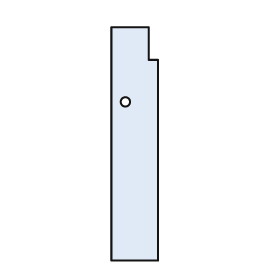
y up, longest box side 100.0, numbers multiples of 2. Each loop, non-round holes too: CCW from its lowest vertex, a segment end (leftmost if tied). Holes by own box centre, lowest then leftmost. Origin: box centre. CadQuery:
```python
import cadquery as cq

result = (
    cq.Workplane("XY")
    .moveTo(-10.0, -50.0)
    .lineTo(10.0, -50.0)
    .lineTo(10.0, 36.0)
    .lineTo(6.0, 36.0)
    .lineTo(6.0, 50.0)
    .lineTo(-10.0, 50.0)
    .close()
    .moveTo(-4.0, 18.0)
    .circle(2.0)
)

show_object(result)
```